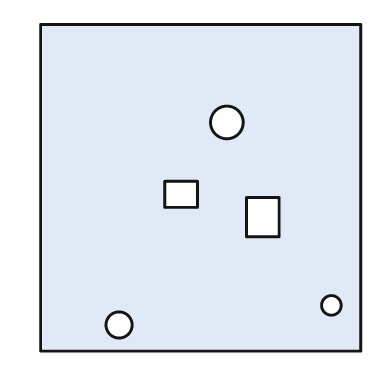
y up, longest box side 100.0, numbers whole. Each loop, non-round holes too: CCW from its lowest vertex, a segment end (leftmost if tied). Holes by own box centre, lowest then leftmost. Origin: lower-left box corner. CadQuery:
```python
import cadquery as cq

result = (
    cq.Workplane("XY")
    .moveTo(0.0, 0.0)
    .lineTo(98.0, 0.0)
    .lineTo(98.0, 100.0)
    .lineTo(0.0, 100.0)
    .close()
    .moveTo(24.0, 8.0)
    .circle(4.0)
    .moveTo(89.0, 14.0)
    .circle(3.0)
    .moveTo(63.0, 35.0)
    .lineTo(73.0, 35.0)
    .lineTo(73.0, 47.0)
    .lineTo(63.0, 47.0)
    .close()
    .moveTo(38.0, 44.0)
    .lineTo(48.0, 44.0)
    .lineTo(48.0, 52.0)
    .lineTo(38.0, 52.0)
    .close()
    .moveTo(57.0, 70.0)
    .circle(5.0)
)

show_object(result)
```